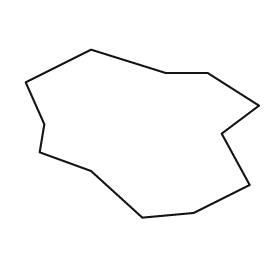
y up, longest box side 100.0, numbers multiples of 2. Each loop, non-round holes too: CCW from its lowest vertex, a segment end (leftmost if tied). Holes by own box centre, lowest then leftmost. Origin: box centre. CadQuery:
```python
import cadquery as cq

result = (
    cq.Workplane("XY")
    .moveTo(0.0, -36.0)
    .lineTo(22.0, -34.0)
    .lineTo(46.0, -22.0)
    .lineTo(34.0, 0.0)
    .lineTo(50.0, 12.0)
    .lineTo(28.0, 26.0)
    .lineTo(10.0, 26.0)
    .lineTo(-22.0, 36.0)
    .lineTo(-50.0, 22.0)
    .lineTo(-42.0, 4.0)
    .lineTo(-44.0, -8.0)
    .lineTo(-22.0, -16.0)
    .close()
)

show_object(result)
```